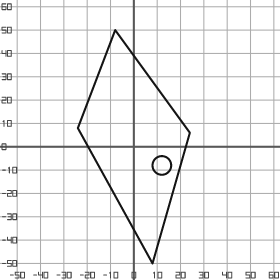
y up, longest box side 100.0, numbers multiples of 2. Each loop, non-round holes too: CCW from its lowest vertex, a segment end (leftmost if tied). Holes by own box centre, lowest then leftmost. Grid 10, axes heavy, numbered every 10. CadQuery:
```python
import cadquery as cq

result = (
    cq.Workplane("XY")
    .moveTo(8.0, -50.0)
    .lineTo(24.0, 6.0)
    .lineTo(-8.0, 50.0)
    .lineTo(-24.0, 8.0)
    .close()
    .moveTo(12.0, -8.0)
    .circle(4.0)
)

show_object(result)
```